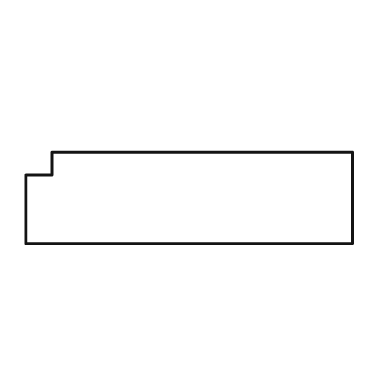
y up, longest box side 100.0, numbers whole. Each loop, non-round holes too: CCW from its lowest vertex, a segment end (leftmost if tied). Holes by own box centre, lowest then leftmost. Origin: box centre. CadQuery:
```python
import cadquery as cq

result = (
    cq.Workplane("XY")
    .moveTo(-50.0, -14.0)
    .lineTo(50.0, -14.0)
    .lineTo(50.0, 14.0)
    .lineTo(-42.0, 14.0)
    .lineTo(-42.0, 7.0)
    .lineTo(-50.0, 7.0)
    .close()
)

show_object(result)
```